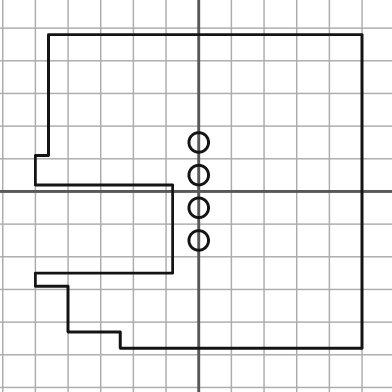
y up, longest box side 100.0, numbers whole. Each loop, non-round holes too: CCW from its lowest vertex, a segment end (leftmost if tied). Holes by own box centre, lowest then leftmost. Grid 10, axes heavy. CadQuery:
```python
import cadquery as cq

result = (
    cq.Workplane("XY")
    .moveTo(-24.0, -48.0)
    .lineTo(50.0, -48.0)
    .lineTo(50.0, 48.0)
    .lineTo(-46.0, 48.0)
    .lineTo(-46.0, 11.0)
    .lineTo(-50.0, 11.0)
    .lineTo(-50.0, 2.0)
    .lineTo(-8.0, 2.0)
    .lineTo(-8.0, -25.0)
    .lineTo(-50.0, -25.0)
    .lineTo(-50.0, -29.0)
    .lineTo(-40.0, -29.0)
    .lineTo(-40.0, -43.0)
    .lineTo(-24.0, -43.0)
    .close()
    .moveTo(0.0, -15.0)
    .circle(3.0)
    .moveTo(0.0, -5.0)
    .circle(3.0)
    .moveTo(0.0, 5.0)
    .circle(3.0)
    .moveTo(0.0, 15.0)
    .circle(3.0)
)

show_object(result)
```